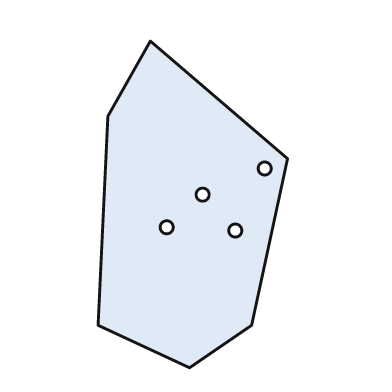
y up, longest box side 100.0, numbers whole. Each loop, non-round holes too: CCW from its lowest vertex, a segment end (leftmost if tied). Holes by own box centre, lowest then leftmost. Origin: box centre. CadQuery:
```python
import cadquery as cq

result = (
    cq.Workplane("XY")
    .moveTo(-1.0, -50.0)
    .lineTo(18.0, -37.0)
    .lineTo(29.0, 14.0)
    .lineTo(-13.0, 50.0)
    .lineTo(-26.0, 27.0)
    .lineTo(-29.0, -37.0)
    .close()
    .moveTo(13.0, -8.0)
    .circle(2.0)
    .moveTo(-8.0, -7.0)
    .circle(2.0)
    .moveTo(3.0, 3.0)
    .circle(2.0)
    .moveTo(22.0, 11.0)
    .circle(2.0)
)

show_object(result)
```